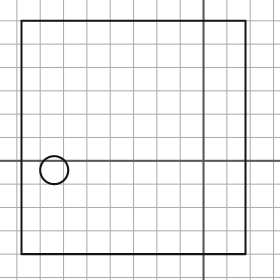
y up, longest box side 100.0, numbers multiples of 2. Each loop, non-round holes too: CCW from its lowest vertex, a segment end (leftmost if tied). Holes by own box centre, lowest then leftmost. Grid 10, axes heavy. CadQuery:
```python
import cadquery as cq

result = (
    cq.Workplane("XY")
    .moveTo(-78.0, -40.0)
    .lineTo(18.0, -40.0)
    .lineTo(18.0, 60.0)
    .lineTo(-78.0, 60.0)
    .close()
    .moveTo(-64.0, -4.0)
    .circle(6.0)
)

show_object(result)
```